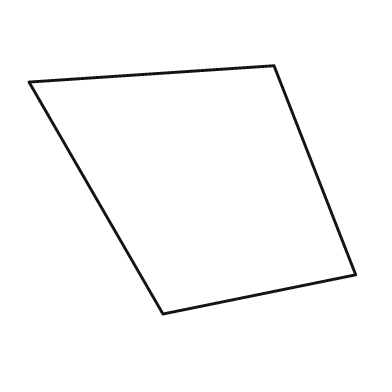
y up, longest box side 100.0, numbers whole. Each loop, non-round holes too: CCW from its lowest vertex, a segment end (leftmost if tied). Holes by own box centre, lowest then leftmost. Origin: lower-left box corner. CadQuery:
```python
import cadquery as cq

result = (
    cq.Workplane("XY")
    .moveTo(41.0, 0.0)
    .lineTo(100.0, 12.0)
    .lineTo(75.0, 76.0)
    .lineTo(0.0, 71.0)
    .close()
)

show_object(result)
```